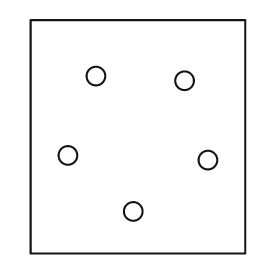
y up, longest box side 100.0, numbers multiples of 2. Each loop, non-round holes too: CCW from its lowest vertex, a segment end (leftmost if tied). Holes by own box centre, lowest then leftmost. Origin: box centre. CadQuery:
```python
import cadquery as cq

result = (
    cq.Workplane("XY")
    .moveTo(-46.0, -50.0)
    .lineTo(46.0, -50.0)
    .lineTo(46.0, 50.0)
    .lineTo(-46.0, 50.0)
    .close()
    .moveTo(-2.0, -32.0)
    .circle(4.0)
    .moveTo(30.0, -10.0)
    .circle(4.0)
    .moveTo(-30.0, -8.0)
    .circle(4.0)
    .moveTo(20.0, 24.0)
    .circle(4.0)
    .moveTo(-18.0, 26.0)
    .circle(4.0)
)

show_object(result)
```